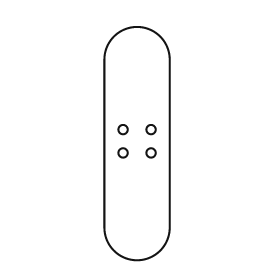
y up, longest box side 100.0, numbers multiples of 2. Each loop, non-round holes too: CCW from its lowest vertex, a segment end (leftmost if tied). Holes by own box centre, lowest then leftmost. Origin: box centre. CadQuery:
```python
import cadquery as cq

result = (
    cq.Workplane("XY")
    .moveTo(-14.0, -36.0)
    .threePointArc((0.0, -50.0), (14.0, -36.0))
    .lineTo(14.0, 36.0)
    .threePointArc((0.0, 50.0), (-14.0, 36.0))
    .close()
    .moveTo(-6.0, -4.0)
    .circle(2.0)
    .moveTo(6.0, -4.0)
    .circle(2.0)
    .moveTo(-6.0, 6.0)
    .circle(2.0)
    .moveTo(6.0, 6.0)
    .circle(2.0)
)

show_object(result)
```